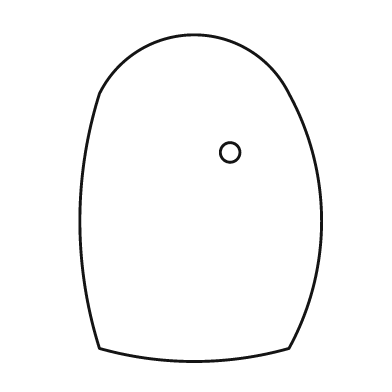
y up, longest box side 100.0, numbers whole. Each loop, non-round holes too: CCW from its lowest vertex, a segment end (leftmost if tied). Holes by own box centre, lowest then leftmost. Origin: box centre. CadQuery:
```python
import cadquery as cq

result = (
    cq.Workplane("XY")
    .moveTo(-31.0, -46.0)
    .threePointArc((-2.0, -50.0), (27.0, -46.0))
    .threePointArc((37.0, -7.0), (27.0, 32.0))
    .threePointArc((-2.0, 50.0), (-31.0, 32.0))
    .threePointArc((-37.0, -7.0), (-31.0, -46.0))
    .close()
    .moveTo(9.0, 14.0)
    .circle(3.0)
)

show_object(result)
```